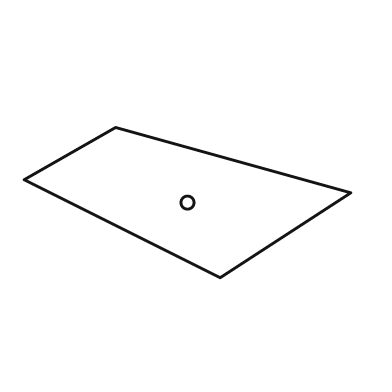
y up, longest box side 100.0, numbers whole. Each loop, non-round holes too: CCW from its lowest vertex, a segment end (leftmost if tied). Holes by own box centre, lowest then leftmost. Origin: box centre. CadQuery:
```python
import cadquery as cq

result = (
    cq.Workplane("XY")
    .moveTo(10.0, -23.0)
    .lineTo(50.0, 3.0)
    .lineTo(-22.0, 23.0)
    .lineTo(-50.0, 7.0)
    .close()
    .moveTo(0.0, 0.0)
    .circle(2.0)
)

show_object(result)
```